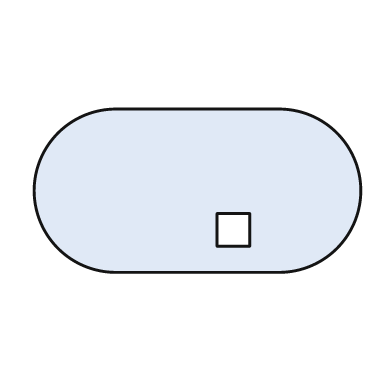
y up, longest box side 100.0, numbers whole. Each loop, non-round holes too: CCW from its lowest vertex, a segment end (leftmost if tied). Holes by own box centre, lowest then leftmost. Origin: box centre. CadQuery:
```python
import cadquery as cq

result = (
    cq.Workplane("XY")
    .moveTo(-25.0, -25.0)
    .lineTo(25.0, -25.0)
    .threePointArc((50.0, 0.0), (25.0, 25.0))
    .lineTo(-25.0, 25.0)
    .threePointArc((-50.0, 0.0), (-25.0, -25.0))
    .close()
    .moveTo(6.0, -17.0)
    .lineTo(16.0, -17.0)
    .lineTo(16.0, -7.0)
    .lineTo(6.0, -7.0)
    .close()
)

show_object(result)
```